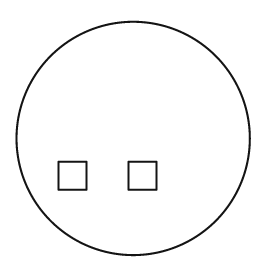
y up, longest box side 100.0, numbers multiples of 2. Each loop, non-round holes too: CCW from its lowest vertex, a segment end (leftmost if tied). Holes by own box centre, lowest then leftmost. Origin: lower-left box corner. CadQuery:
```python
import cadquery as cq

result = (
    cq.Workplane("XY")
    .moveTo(50.0, 50.0)
    .circle(50.0)
    .moveTo(18.0, 28.0)
    .lineTo(30.0, 28.0)
    .lineTo(30.0, 40.0)
    .lineTo(18.0, 40.0)
    .close()
    .moveTo(48.0, 28.0)
    .lineTo(60.0, 28.0)
    .lineTo(60.0, 40.0)
    .lineTo(48.0, 40.0)
    .close()
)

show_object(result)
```